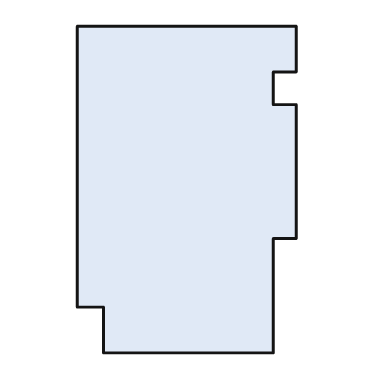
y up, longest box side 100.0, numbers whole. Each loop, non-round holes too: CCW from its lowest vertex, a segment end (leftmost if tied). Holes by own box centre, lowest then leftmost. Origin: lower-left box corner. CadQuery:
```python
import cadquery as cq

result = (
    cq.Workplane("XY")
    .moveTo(8.0, 0.0)
    .lineTo(60.0, 0.0)
    .lineTo(60.0, 35.0)
    .lineTo(67.0, 35.0)
    .lineTo(67.0, 76.0)
    .lineTo(60.0, 76.0)
    .lineTo(60.0, 86.0)
    .lineTo(67.0, 86.0)
    .lineTo(67.0, 100.0)
    .lineTo(0.0, 100.0)
    .lineTo(0.0, 14.0)
    .lineTo(8.0, 14.0)
    .close()
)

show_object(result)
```